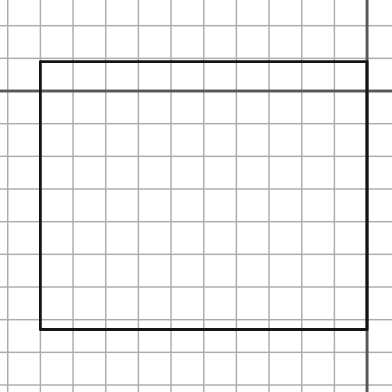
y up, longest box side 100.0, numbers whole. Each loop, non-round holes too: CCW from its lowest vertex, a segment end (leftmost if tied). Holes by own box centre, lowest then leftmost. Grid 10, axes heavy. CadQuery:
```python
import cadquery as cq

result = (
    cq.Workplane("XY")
    .moveTo(-100.0, -73.0)
    .lineTo(0.0, -73.0)
    .lineTo(0.0, 9.0)
    .lineTo(-100.0, 9.0)
    .close()
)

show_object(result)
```